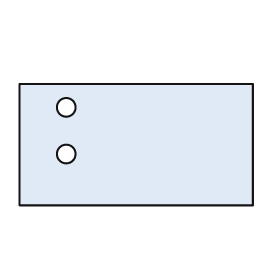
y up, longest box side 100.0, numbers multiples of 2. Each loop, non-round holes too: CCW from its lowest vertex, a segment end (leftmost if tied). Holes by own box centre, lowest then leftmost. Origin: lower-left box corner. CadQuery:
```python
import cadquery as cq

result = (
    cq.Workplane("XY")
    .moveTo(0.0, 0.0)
    .lineTo(100.0, 0.0)
    .lineTo(100.0, 52.0)
    .lineTo(0.0, 52.0)
    .close()
    .moveTo(20.0, 22.0)
    .circle(4.0)
    .moveTo(20.0, 42.0)
    .circle(4.0)
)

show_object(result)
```